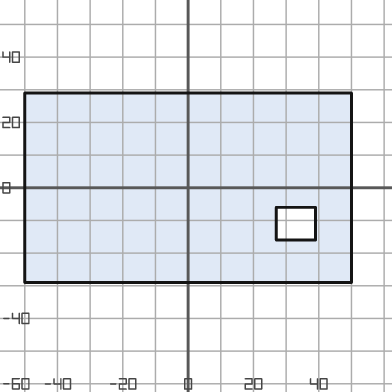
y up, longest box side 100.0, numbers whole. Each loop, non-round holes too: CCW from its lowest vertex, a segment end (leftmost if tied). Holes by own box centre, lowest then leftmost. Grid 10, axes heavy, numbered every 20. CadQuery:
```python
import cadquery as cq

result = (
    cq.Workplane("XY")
    .moveTo(-50.0, -29.0)
    .lineTo(50.0, -29.0)
    .lineTo(50.0, 29.0)
    .lineTo(-50.0, 29.0)
    .close()
    .moveTo(27.0, -16.0)
    .lineTo(39.0, -16.0)
    .lineTo(39.0, -6.0)
    .lineTo(27.0, -6.0)
    .close()
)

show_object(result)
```